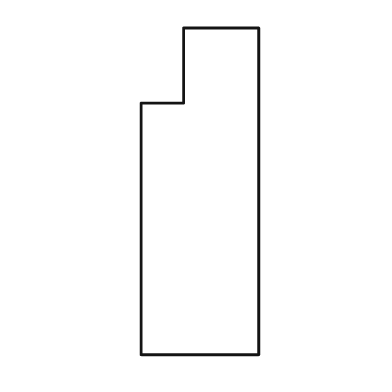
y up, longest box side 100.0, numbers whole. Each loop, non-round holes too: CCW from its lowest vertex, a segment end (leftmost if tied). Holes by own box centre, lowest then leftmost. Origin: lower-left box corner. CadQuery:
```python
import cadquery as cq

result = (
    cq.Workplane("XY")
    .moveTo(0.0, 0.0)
    .lineTo(36.0, 0.0)
    .lineTo(36.0, 100.0)
    .lineTo(13.0, 100.0)
    .lineTo(13.0, 77.0)
    .lineTo(0.0, 77.0)
    .close()
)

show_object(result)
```